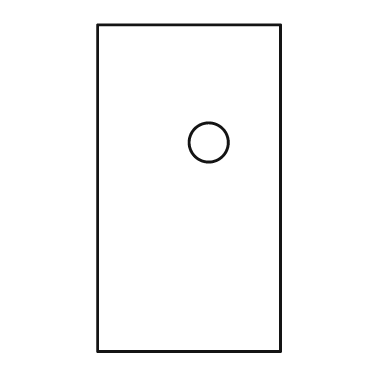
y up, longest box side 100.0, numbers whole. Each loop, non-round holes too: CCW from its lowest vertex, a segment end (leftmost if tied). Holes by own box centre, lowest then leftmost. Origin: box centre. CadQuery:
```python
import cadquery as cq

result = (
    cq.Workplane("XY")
    .moveTo(-28.0, -50.0)
    .lineTo(28.0, -50.0)
    .lineTo(28.0, 50.0)
    .lineTo(-28.0, 50.0)
    .close()
    .moveTo(6.0, 14.0)
    .circle(6.0)
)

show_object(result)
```